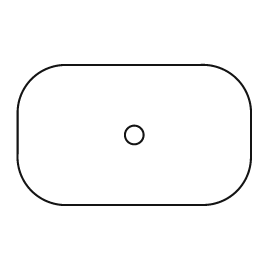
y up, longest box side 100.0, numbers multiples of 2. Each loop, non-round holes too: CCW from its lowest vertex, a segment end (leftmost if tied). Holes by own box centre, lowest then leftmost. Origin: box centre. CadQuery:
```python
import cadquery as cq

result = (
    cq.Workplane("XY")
    .moveTo(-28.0, -30.0)
    .lineTo(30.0, -30.0)
    .threePointArc((44.0, -24.0), (50.0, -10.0))
    .lineTo(50.0, 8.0)
    .threePointArc((44.0, 24.0), (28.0, 30.0))
    .lineTo(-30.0, 30.0)
    .threePointArc((-44.0, 24.0), (-50.0, 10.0))
    .lineTo(-50.0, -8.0)
    .threePointArc((-44.0, -24.0), (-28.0, -30.0))
    .close()
    .moveTo(0.0, 0.0)
    .circle(4.0)
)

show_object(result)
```